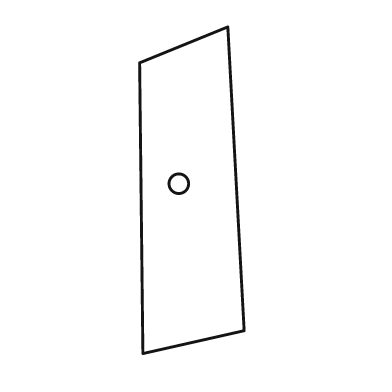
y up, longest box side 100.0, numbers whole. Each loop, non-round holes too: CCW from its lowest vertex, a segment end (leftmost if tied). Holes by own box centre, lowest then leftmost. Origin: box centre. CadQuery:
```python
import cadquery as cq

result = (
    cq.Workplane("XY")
    .moveTo(-15.0, -50.0)
    .lineTo(16.0, -43.0)
    .lineTo(11.0, 50.0)
    .lineTo(-16.0, 39.0)
    .close()
    .moveTo(-4.0, 2.0)
    .circle(3.0)
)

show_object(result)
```